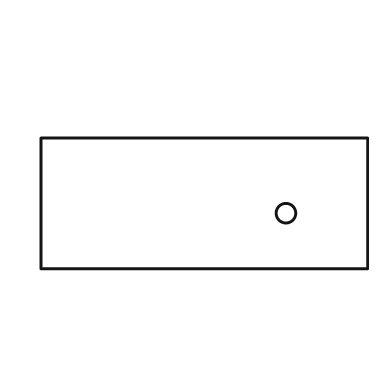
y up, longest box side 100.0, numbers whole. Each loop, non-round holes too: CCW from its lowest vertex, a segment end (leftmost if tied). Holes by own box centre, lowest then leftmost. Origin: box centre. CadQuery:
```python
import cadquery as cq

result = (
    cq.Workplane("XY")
    .moveTo(-50.0, -20.0)
    .lineTo(50.0, -20.0)
    .lineTo(50.0, 20.0)
    .lineTo(-50.0, 20.0)
    .close()
    .moveTo(25.0, -3.0)
    .circle(3.0)
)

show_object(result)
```